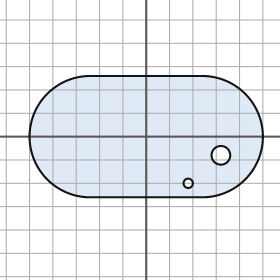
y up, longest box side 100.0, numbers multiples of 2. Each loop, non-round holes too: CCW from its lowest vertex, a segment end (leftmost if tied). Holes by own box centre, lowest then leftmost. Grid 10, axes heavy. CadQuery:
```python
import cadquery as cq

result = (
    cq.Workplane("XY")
    .moveTo(-24.0, -26.0)
    .lineTo(24.0, -26.0)
    .threePointArc((50.0, 0.0), (24.0, 26.0))
    .lineTo(-24.0, 26.0)
    .threePointArc((-50.0, 0.0), (-24.0, -26.0))
    .close()
    .moveTo(18.0, -20.0)
    .circle(2.0)
    .moveTo(32.0, -8.0)
    .circle(4.0)
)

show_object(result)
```